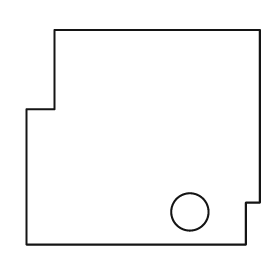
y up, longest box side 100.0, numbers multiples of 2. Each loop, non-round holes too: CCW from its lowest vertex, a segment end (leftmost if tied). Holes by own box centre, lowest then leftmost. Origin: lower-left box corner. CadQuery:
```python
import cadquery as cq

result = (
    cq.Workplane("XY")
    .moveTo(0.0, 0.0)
    .lineTo(94.0, 0.0)
    .lineTo(94.0, 18.0)
    .lineTo(100.0, 18.0)
    .lineTo(100.0, 92.0)
    .lineTo(12.0, 92.0)
    .lineTo(12.0, 58.0)
    .lineTo(0.0, 58.0)
    .close()
    .moveTo(70.0, 14.0)
    .circle(8.0)
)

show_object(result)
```